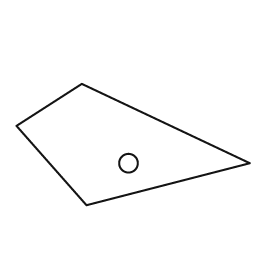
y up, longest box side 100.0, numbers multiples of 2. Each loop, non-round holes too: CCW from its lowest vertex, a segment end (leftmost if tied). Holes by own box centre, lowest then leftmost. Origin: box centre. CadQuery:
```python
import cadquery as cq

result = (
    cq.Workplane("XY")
    .moveTo(-20.0, -26.0)
    .lineTo(50.0, -8.0)
    .lineTo(-22.0, 26.0)
    .lineTo(-50.0, 8.0)
    .close()
    .moveTo(-2.0, -8.0)
    .circle(4.0)
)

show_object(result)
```